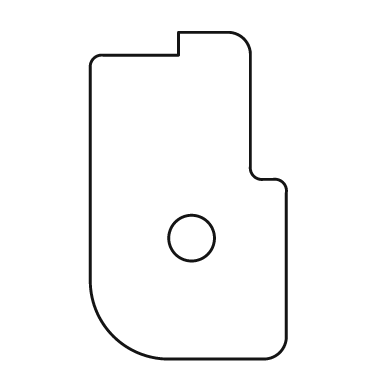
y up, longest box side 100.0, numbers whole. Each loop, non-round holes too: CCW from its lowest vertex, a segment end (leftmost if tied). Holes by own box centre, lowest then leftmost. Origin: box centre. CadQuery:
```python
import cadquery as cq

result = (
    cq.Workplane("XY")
    .moveTo(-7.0, -50.0)
    .lineTo(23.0, -50.0)
    .threePointArc((28.0, -48.0), (30.0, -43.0))
    .lineTo(30.0, 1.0)
    .threePointArc((29.0, 4.0), (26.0, 5.0))
    .lineTo(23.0, 5.0)
    .threePointArc((20.0, 6.0), (19.0, 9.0))
    .lineTo(19.0, 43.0)
    .threePointArc((17.0, 48.0), (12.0, 50.0))
    .lineTo(-3.0, 50.0)
    .lineTo(-3.0, 43.0)
    .lineTo(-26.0, 43.0)
    .threePointArc((-29.0, 42.0), (-30.0, 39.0))
    .lineTo(-30.0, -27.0)
    .threePointArc((-23.0, -43.0), (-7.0, -50.0))
    .close()
    .moveTo(1.0, -13.0)
    .circle(7.0)
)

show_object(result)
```